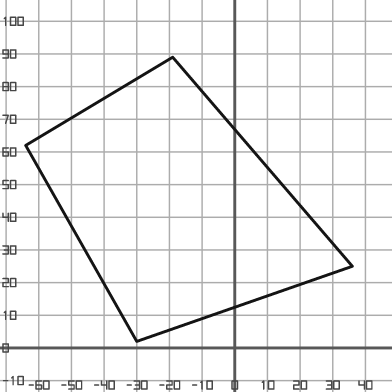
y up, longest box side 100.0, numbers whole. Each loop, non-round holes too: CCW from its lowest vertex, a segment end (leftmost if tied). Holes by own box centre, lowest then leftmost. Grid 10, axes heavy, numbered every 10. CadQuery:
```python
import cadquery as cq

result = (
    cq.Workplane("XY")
    .moveTo(-30.0, 2.0)
    .lineTo(36.0, 25.0)
    .lineTo(-19.0, 89.0)
    .lineTo(-64.0, 62.0)
    .close()
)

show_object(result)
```